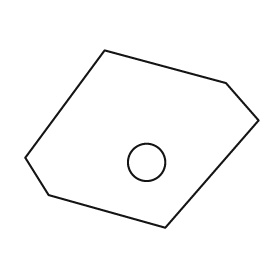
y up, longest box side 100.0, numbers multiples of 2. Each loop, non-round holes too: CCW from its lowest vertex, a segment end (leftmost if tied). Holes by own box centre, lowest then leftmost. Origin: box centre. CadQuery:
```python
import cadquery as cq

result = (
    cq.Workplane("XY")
    .moveTo(10.0, -38.0)
    .lineTo(50.0, 8.0)
    .lineTo(36.0, 24.0)
    .lineTo(-16.0, 38.0)
    .lineTo(-50.0, -8.0)
    .lineTo(-40.0, -24.0)
    .close()
    .moveTo(2.0, -10.0)
    .circle(8.0)
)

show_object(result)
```